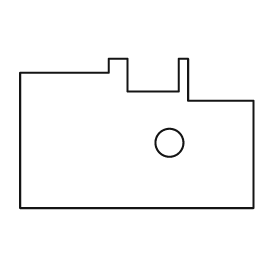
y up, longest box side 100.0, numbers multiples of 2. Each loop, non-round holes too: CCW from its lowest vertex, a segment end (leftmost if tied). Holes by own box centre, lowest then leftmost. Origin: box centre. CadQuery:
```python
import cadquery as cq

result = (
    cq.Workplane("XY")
    .moveTo(-50.0, -32.0)
    .lineTo(50.0, -32.0)
    .lineTo(50.0, 14.0)
    .lineTo(22.0, 14.0)
    .lineTo(22.0, 32.0)
    .lineTo(18.0, 32.0)
    .lineTo(18.0, 18.0)
    .lineTo(-4.0, 18.0)
    .lineTo(-4.0, 32.0)
    .lineTo(-12.0, 32.0)
    .lineTo(-12.0, 26.0)
    .lineTo(-50.0, 26.0)
    .close()
    .moveTo(14.0, -4.0)
    .circle(6.0)
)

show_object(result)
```